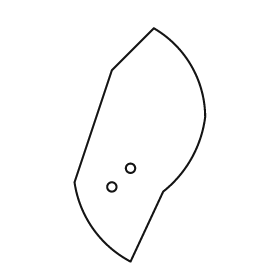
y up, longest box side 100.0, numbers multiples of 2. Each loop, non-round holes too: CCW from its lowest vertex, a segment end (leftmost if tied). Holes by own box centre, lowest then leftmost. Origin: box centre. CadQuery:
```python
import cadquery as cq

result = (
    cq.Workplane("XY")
    .moveTo(-4.0, -50.0)
    .lineTo(10.0, -20.0)
    .threePointArc((22.0, -6.0), (28.0, 12.0))
    .threePointArc((22.0, 34.0), (6.0, 50.0))
    .lineTo(-12.0, 32.0)
    .lineTo(-28.0, -16.0)
    .threePointArc((-20.0, -36.0), (-4.0, -50.0))
    .close()
    .moveTo(-12.0, -18.0)
    .circle(2.0)
    .moveTo(-4.0, -10.0)
    .circle(2.0)
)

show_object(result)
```